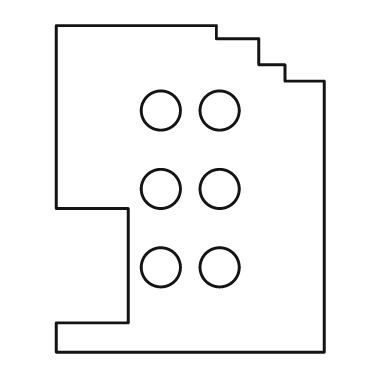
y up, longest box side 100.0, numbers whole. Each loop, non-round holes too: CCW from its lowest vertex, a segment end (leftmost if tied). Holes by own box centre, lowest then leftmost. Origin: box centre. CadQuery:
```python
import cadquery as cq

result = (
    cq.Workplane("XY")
    .moveTo(-41.0, -50.0)
    .lineTo(41.0, -50.0)
    .lineTo(41.0, 33.0)
    .lineTo(29.0, 33.0)
    .lineTo(29.0, 38.0)
    .lineTo(21.0, 38.0)
    .lineTo(21.0, 46.0)
    .lineTo(8.0, 46.0)
    .lineTo(8.0, 50.0)
    .lineTo(-41.0, 50.0)
    .lineTo(-41.0, -6.0)
    .lineTo(-19.0, -6.0)
    .lineTo(-19.0, -41.0)
    .lineTo(-41.0, -41.0)
    .close()
    .moveTo(-9.0, -24.0)
    .circle(6.0)
    .moveTo(9.0, -24.0)
    .circle(6.0)
    .moveTo(-9.0, 0.0)
    .circle(6.0)
    .moveTo(9.0, 0.0)
    .circle(6.0)
    .moveTo(-9.0, 24.0)
    .circle(6.0)
    .moveTo(9.0, 24.0)
    .circle(6.0)
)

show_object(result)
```